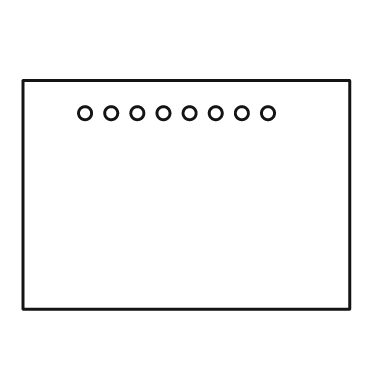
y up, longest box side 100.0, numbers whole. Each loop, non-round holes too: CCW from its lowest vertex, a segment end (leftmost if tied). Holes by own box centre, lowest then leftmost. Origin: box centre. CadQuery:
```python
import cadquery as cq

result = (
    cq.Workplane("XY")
    .moveTo(-50.0, -35.0)
    .lineTo(50.0, -35.0)
    .lineTo(50.0, 35.0)
    .lineTo(-50.0, 35.0)
    .close()
    .moveTo(-31.0, 25.0)
    .circle(2.0)
    .moveTo(-23.0, 25.0)
    .circle(2.0)
    .moveTo(-15.0, 25.0)
    .circle(2.0)
    .moveTo(-7.0, 25.0)
    .circle(2.0)
    .moveTo(1.0, 25.0)
    .circle(2.0)
    .moveTo(9.0, 25.0)
    .circle(2.0)
    .moveTo(17.0, 25.0)
    .circle(2.0)
    .moveTo(25.0, 25.0)
    .circle(2.0)
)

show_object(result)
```